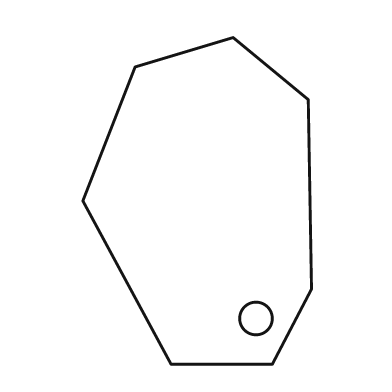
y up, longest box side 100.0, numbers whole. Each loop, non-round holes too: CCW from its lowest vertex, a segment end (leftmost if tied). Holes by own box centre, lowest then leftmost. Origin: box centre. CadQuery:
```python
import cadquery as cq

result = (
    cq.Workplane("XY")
    .moveTo(-8.0, -50.0)
    .lineTo(23.0, -50.0)
    .lineTo(35.0, -27.0)
    .lineTo(34.0, 31.0)
    .lineTo(11.0, 50.0)
    .lineTo(-19.0, 41.0)
    .lineTo(-35.0, 0.0)
    .close()
    .moveTo(18.0, -36.0)
    .circle(5.0)
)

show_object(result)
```